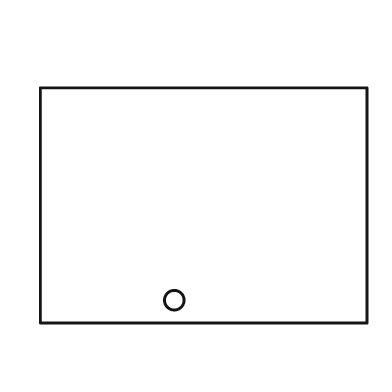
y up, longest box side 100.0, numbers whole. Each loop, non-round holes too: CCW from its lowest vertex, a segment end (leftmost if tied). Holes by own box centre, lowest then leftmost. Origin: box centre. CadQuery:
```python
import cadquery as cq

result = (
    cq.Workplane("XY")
    .moveTo(-50.0, -36.0)
    .lineTo(50.0, -36.0)
    .lineTo(50.0, 36.0)
    .lineTo(-50.0, 36.0)
    .close()
    .moveTo(-9.0, -29.0)
    .circle(3.0)
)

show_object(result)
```